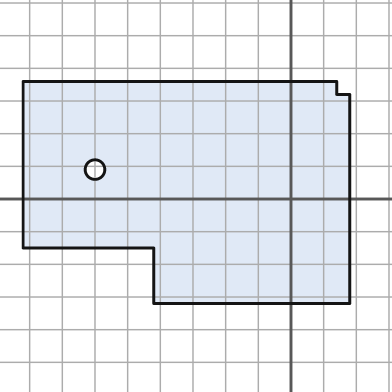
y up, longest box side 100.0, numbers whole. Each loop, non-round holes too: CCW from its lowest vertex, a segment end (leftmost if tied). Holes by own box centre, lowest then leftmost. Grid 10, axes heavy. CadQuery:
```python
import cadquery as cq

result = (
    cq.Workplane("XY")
    .moveTo(-42.0, -32.0)
    .lineTo(18.0, -32.0)
    .lineTo(18.0, 32.0)
    .lineTo(14.0, 32.0)
    .lineTo(14.0, 36.0)
    .lineTo(-82.0, 36.0)
    .lineTo(-82.0, -15.0)
    .lineTo(-42.0, -15.0)
    .close()
    .moveTo(-60.0, 9.0)
    .circle(3.0)
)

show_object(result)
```